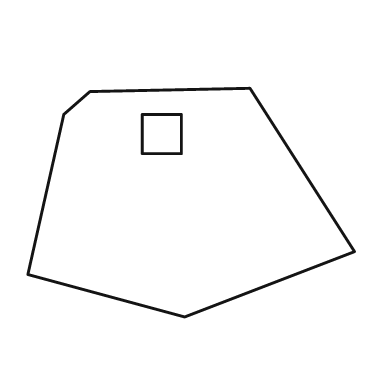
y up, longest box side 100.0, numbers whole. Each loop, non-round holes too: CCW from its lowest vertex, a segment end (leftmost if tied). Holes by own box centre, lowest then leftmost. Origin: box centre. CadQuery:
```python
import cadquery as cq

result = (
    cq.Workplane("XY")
    .moveTo(-2.0, -35.0)
    .lineTo(50.0, -15.0)
    .lineTo(18.0, 35.0)
    .lineTo(-31.0, 34.0)
    .lineTo(-39.0, 27.0)
    .lineTo(-50.0, -22.0)
    .close()
    .moveTo(-15.0, 15.0)
    .lineTo(-3.0, 15.0)
    .lineTo(-3.0, 27.0)
    .lineTo(-15.0, 27.0)
    .close()
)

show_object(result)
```